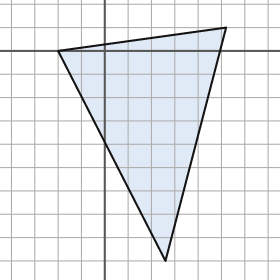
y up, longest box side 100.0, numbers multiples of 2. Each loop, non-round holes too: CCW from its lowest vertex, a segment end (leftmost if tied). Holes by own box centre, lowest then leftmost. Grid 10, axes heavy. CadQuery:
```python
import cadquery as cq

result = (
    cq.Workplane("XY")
    .moveTo(26.0, -90.0)
    .lineTo(52.0, 10.0)
    .lineTo(-20.0, 0.0)
    .close()
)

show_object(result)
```